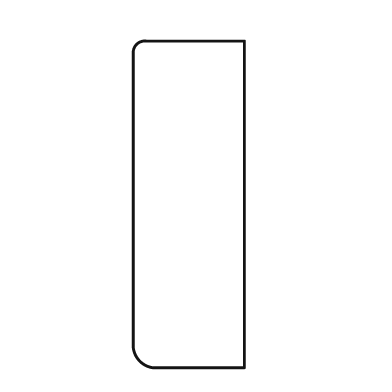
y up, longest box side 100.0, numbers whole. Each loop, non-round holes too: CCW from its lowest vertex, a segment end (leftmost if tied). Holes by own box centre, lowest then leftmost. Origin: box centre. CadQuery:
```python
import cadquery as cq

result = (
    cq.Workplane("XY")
    .moveTo(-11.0, -50.0)
    .lineTo(17.0, -50.0)
    .lineTo(17.0, 50.0)
    .lineTo(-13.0, 50.0)
    .threePointArc((-16.0, 49.0), (-17.0, 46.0))
    .lineTo(-17.0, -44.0)
    .threePointArc((-15.0, -48.0), (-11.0, -50.0))
    .close()
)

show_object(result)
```